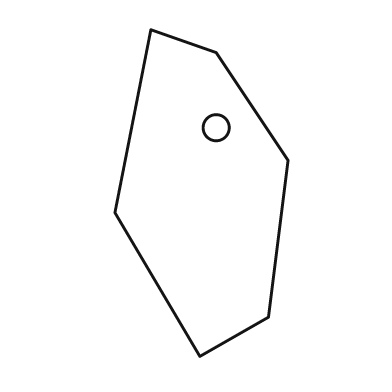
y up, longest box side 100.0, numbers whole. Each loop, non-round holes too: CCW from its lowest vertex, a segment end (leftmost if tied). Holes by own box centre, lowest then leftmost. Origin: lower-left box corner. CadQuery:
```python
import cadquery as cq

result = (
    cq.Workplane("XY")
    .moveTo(26.0, 0.0)
    .lineTo(47.0, 12.0)
    .lineTo(53.0, 60.0)
    .lineTo(31.0, 93.0)
    .lineTo(11.0, 100.0)
    .lineTo(0.0, 44.0)
    .close()
    .moveTo(31.0, 70.0)
    .circle(4.0)
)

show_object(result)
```